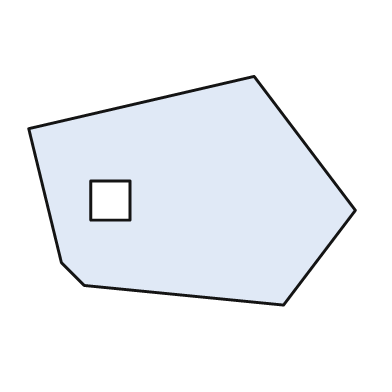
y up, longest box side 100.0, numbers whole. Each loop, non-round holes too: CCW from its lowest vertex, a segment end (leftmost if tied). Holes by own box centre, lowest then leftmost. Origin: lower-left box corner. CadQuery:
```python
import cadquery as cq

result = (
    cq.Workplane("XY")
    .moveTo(78.0, 0.0)
    .lineTo(100.0, 29.0)
    .lineTo(69.0, 70.0)
    .lineTo(0.0, 54.0)
    .lineTo(10.0, 13.0)
    .lineTo(17.0, 6.0)
    .close()
    .moveTo(19.0, 26.0)
    .lineTo(31.0, 26.0)
    .lineTo(31.0, 38.0)
    .lineTo(19.0, 38.0)
    .close()
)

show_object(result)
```